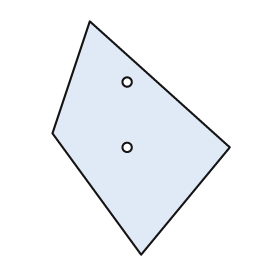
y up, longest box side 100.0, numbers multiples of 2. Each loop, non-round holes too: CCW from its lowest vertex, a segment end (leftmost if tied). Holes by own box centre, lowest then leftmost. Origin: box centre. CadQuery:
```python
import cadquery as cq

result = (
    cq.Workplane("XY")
    .moveTo(0.0, -50.0)
    .lineTo(38.0, -4.0)
    .lineTo(-22.0, 50.0)
    .lineTo(-38.0, 2.0)
    .close()
    .moveTo(-6.0, -4.0)
    .circle(2.0)
    .moveTo(-6.0, 24.0)
    .circle(2.0)
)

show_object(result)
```